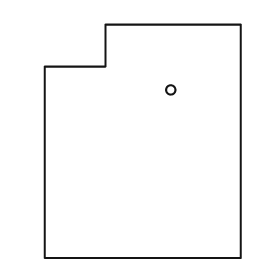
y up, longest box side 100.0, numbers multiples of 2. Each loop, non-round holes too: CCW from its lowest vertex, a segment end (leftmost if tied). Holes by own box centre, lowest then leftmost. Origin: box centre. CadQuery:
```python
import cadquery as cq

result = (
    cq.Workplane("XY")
    .moveTo(-42.0, -50.0)
    .lineTo(42.0, -50.0)
    .lineTo(42.0, 50.0)
    .lineTo(-16.0, 50.0)
    .lineTo(-16.0, 32.0)
    .lineTo(-42.0, 32.0)
    .close()
    .moveTo(12.0, 22.0)
    .circle(2.0)
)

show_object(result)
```